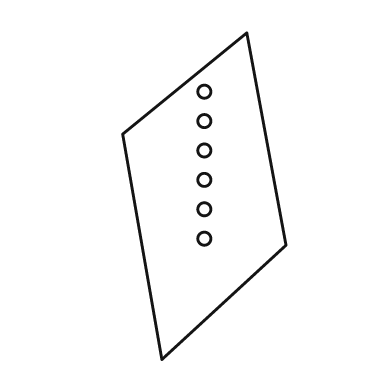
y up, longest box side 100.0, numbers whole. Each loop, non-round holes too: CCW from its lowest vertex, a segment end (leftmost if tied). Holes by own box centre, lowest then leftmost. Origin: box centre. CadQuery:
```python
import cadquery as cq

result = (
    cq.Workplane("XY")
    .moveTo(-13.0, -50.0)
    .lineTo(25.0, -15.0)
    .lineTo(13.0, 50.0)
    .lineTo(-25.0, 19.0)
    .close()
    .moveTo(0.0, -13.0)
    .circle(2.0)
    .moveTo(0.0, -4.0)
    .circle(2.0)
    .moveTo(0.0, 5.0)
    .circle(2.0)
    .moveTo(0.0, 14.0)
    .circle(2.0)
    .moveTo(0.0, 23.0)
    .circle(2.0)
    .moveTo(0.0, 32.0)
    .circle(2.0)
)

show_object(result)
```